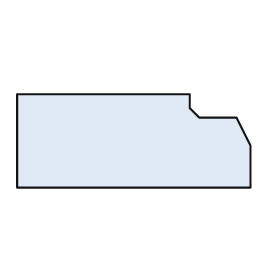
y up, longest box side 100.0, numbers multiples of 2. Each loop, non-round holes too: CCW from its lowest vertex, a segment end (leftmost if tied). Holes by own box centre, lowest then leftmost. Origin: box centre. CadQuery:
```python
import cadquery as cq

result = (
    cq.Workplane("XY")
    .moveTo(-50.0, -20.0)
    .lineTo(50.0, -20.0)
    .lineTo(50.0, -2.0)
    .lineTo(44.0, 10.0)
    .lineTo(28.0, 10.0)
    .lineTo(24.0, 14.0)
    .lineTo(24.0, 20.0)
    .lineTo(-50.0, 20.0)
    .close()
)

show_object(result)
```